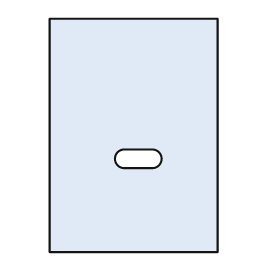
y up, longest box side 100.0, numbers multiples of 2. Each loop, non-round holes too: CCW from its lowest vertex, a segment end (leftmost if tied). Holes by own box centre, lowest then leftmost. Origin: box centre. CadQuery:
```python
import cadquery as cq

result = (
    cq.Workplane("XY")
    .moveTo(-36.0, -50.0)
    .lineTo(36.0, -50.0)
    .lineTo(36.0, 50.0)
    .lineTo(-36.0, 50.0)
    .close()
    .moveTo(-4.0, -14.0)
    .lineTo(8.0, -14.0)
    .threePointArc((12.0, -10.0), (8.0, -6.0))
    .lineTo(-4.0, -6.0)
    .threePointArc((-8.0, -10.0), (-4.0, -14.0))
    .close()
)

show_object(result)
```